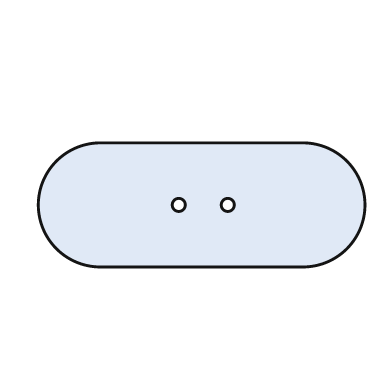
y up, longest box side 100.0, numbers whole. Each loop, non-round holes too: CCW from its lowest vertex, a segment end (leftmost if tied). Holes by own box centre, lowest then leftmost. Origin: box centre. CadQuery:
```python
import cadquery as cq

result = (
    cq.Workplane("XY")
    .moveTo(-31.0, -19.0)
    .lineTo(31.0, -19.0)
    .threePointArc((50.0, 0.0), (31.0, 19.0))
    .lineTo(-31.0, 19.0)
    .threePointArc((-50.0, 0.0), (-31.0, -19.0))
    .close()
    .moveTo(-7.0, 0.0)
    .circle(2.0)
    .moveTo(8.0, 0.0)
    .circle(2.0)
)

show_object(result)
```